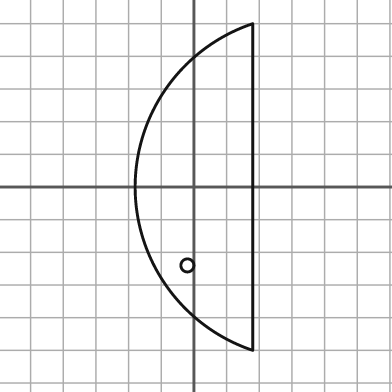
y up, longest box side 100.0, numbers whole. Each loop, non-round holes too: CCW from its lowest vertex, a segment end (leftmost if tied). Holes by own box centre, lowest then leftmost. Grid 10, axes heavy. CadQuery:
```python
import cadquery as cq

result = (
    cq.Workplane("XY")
    .moveTo(18.0, -50.0)
    .lineTo(18.0, 50.0)
    .threePointArc((-18.0, 0.0), (18.0, -50.0))
    .close()
    .moveTo(-2.0, -24.0)
    .circle(2.0)
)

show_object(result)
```